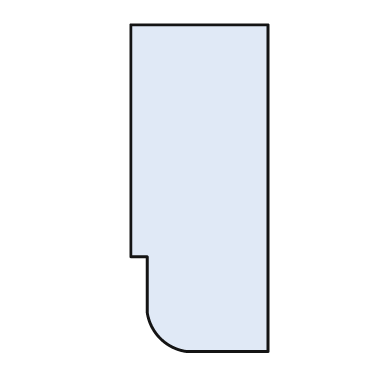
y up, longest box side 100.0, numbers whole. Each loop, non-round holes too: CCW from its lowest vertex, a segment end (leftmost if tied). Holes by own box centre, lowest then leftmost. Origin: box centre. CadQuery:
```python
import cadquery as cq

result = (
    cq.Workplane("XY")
    .moveTo(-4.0, -50.0)
    .lineTo(21.0, -50.0)
    .lineTo(21.0, 50.0)
    .lineTo(-21.0, 50.0)
    .lineTo(-21.0, -21.0)
    .lineTo(-16.0, -21.0)
    .lineTo(-16.0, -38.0)
    .threePointArc((-12.0, -46.0), (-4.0, -50.0))
    .close()
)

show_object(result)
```